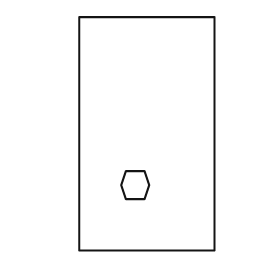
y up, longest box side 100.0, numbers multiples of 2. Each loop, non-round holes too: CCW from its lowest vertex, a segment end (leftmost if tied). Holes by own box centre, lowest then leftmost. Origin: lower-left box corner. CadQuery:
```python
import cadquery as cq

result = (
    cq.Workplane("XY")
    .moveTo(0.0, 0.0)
    .lineTo(58.0, 0.0)
    .lineTo(58.0, 100.0)
    .lineTo(0.0, 100.0)
    .close()
    .moveTo(20.0, 22.0)
    .lineTo(28.0, 22.0)
    .lineTo(30.0, 28.0)
    .lineTo(28.0, 34.0)
    .lineTo(20.0, 34.0)
    .lineTo(18.0, 28.0)
    .close()
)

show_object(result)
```